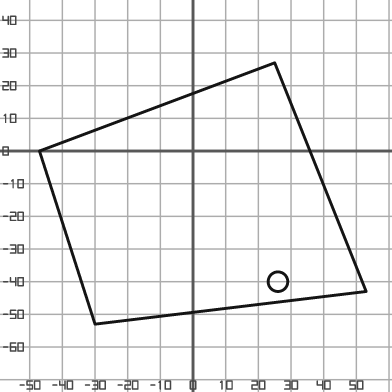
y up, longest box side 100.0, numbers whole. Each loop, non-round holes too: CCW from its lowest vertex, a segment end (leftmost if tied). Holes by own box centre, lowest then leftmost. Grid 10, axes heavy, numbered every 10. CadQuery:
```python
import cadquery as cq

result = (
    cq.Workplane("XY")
    .moveTo(-30.0, -53.0)
    .lineTo(53.0, -43.0)
    .lineTo(25.0, 27.0)
    .lineTo(-47.0, 0.0)
    .close()
    .moveTo(26.0, -40.0)
    .circle(3.0)
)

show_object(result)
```